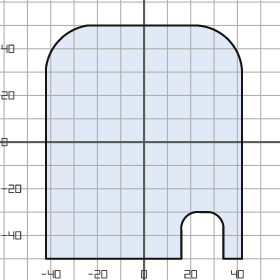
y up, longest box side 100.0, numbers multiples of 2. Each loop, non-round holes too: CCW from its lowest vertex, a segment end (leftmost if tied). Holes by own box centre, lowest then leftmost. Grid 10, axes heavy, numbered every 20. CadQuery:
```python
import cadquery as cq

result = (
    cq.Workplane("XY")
    .moveTo(-42.0, -50.0)
    .lineTo(16.0, -50.0)
    .lineTo(16.0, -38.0)
    .threePointArc((18.0, -32.0), (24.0, -30.0))
    .lineTo(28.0, -30.0)
    .threePointArc((32.0, -32.0), (34.0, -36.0))
    .lineTo(34.0, -50.0)
    .lineTo(42.0, -50.0)
    .lineTo(42.0, 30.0)
    .threePointArc((36.0, 44.0), (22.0, 50.0))
    .lineTo(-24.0, 50.0)
    .threePointArc((-36.0, 44.0), (-42.0, 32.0))
    .close()
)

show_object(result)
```